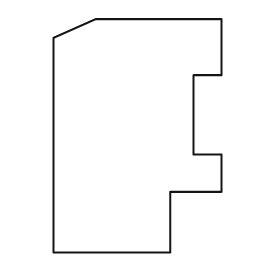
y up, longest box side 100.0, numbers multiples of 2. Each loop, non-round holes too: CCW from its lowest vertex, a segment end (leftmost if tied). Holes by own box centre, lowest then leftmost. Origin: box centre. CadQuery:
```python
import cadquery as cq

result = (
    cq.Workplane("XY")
    .moveTo(-36.0, -50.0)
    .lineTo(14.0, -50.0)
    .lineTo(14.0, -24.0)
    .lineTo(36.0, -24.0)
    .lineTo(36.0, -8.0)
    .lineTo(24.0, -8.0)
    .lineTo(24.0, 26.0)
    .lineTo(36.0, 26.0)
    .lineTo(36.0, 50.0)
    .lineTo(-18.0, 50.0)
    .lineTo(-36.0, 42.0)
    .close()
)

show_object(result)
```